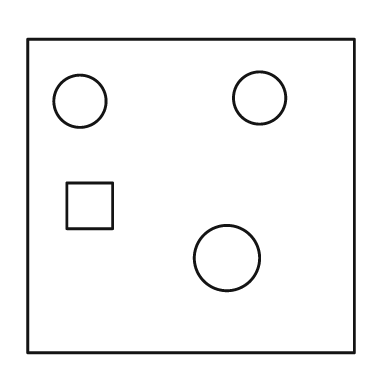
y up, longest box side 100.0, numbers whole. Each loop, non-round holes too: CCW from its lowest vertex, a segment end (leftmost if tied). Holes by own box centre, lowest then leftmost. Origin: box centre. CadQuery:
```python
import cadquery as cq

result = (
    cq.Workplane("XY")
    .moveTo(-50.0, -48.0)
    .lineTo(50.0, -48.0)
    .lineTo(50.0, 48.0)
    .lineTo(-50.0, 48.0)
    .close()
    .moveTo(11.0, -19.0)
    .circle(10.0)
    .moveTo(-38.0, -10.0)
    .lineTo(-24.0, -10.0)
    .lineTo(-24.0, 4.0)
    .lineTo(-38.0, 4.0)
    .close()
    .moveTo(-34.0, 29.0)
    .circle(8.0)
    .moveTo(21.0, 30.0)
    .circle(8.0)
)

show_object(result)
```